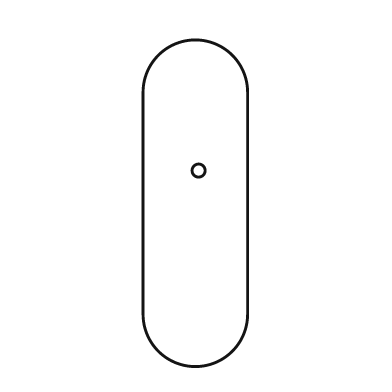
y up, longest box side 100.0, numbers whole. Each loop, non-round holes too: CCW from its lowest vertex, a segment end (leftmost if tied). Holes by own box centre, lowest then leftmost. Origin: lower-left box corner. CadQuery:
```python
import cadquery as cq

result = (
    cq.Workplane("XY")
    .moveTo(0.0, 16.0)
    .threePointArc((16.0, 0.0), (32.0, 16.0))
    .lineTo(32.0, 84.0)
    .threePointArc((16.0, 100.0), (0.0, 84.0))
    .close()
    .moveTo(17.0, 60.0)
    .circle(2.0)
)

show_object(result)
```